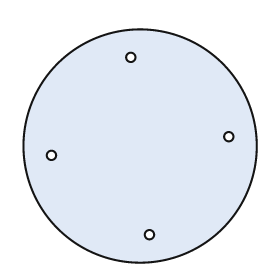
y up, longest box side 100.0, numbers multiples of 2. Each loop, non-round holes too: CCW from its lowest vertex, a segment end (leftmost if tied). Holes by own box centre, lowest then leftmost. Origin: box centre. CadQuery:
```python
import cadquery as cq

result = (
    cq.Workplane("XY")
    .moveTo(0.0, 0.0)
    .circle(50.0)
    .moveTo(4.0, -38.0)
    .circle(2.0)
    .moveTo(-38.0, -4.0)
    .circle(2.0)
    .moveTo(38.0, 4.0)
    .circle(2.0)
    .moveTo(-4.0, 38.0)
    .circle(2.0)
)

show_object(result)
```